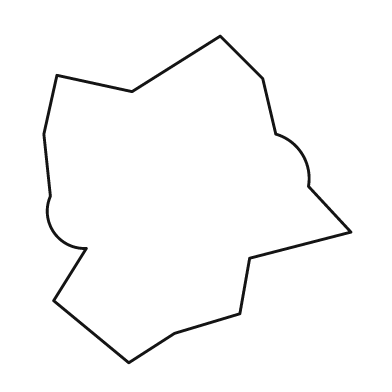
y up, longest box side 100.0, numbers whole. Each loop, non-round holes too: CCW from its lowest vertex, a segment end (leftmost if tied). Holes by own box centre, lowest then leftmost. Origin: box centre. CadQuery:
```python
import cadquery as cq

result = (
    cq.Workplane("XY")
    .moveTo(-21.0, -50.0)
    .lineTo(-7.0, -41.0)
    .lineTo(13.0, -35.0)
    .lineTo(16.0, -18.0)
    .lineTo(47.0, -10.0)
    .lineTo(34.0, 4.0)
    .threePointArc((32.0, 14.0), (24.0, 20.0))
    .lineTo(20.0, 37.0)
    .lineTo(7.0, 50.0)
    .lineTo(-20.0, 33.0)
    .lineTo(-43.0, 38.0)
    .lineTo(-47.0, 20.0)
    .lineTo(-45.0, 1.0)
    .threePointArc((-44.0, -10.0), (-34.0, -15.0))
    .lineTo(-44.0, -31.0)
    .close()
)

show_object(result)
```